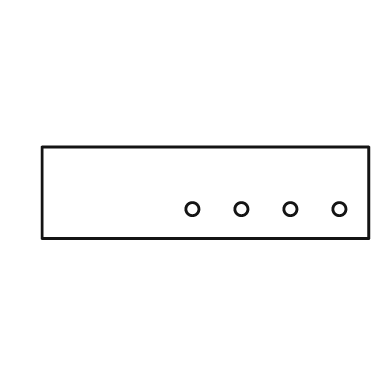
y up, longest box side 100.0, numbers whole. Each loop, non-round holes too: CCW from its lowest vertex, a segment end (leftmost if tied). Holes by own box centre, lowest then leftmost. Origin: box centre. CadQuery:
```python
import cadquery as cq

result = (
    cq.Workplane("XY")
    .moveTo(-50.0, -14.0)
    .lineTo(50.0, -14.0)
    .lineTo(50.0, 14.0)
    .lineTo(-50.0, 14.0)
    .close()
    .moveTo(-4.0, -5.0)
    .circle(2.0)
    .moveTo(11.0, -5.0)
    .circle(2.0)
    .moveTo(26.0, -5.0)
    .circle(2.0)
    .moveTo(41.0, -5.0)
    .circle(2.0)
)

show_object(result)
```